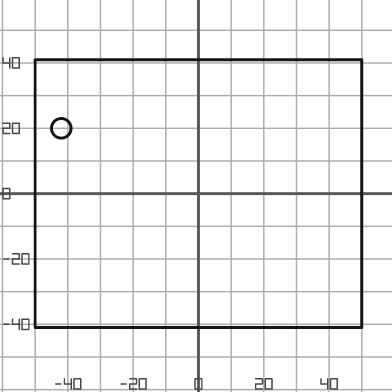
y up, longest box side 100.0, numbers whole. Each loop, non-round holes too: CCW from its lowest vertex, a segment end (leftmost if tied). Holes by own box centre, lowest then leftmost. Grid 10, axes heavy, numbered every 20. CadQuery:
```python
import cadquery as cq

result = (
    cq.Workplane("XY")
    .moveTo(-50.0, -41.0)
    .lineTo(50.0, -41.0)
    .lineTo(50.0, 41.0)
    .lineTo(-50.0, 41.0)
    .close()
    .moveTo(-42.0, 20.0)
    .circle(3.0)
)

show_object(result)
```